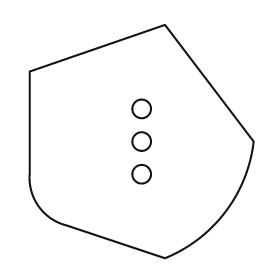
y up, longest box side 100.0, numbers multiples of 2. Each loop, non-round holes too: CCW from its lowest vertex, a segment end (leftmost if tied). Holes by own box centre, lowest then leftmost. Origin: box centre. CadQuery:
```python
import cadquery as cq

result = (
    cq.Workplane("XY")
    .moveTo(10.0, -50.0)
    .threePointArc((36.0, -30.0), (48.0, 0.0))
    .lineTo(10.0, 50.0)
    .lineTo(-48.0, 30.0)
    .lineTo(-48.0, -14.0)
    .threePointArc((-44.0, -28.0), (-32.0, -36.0))
    .close()
    .moveTo(0.0, -14.0)
    .circle(4.0)
    .moveTo(0.0, 0.0)
    .circle(4.0)
    .moveTo(0.0, 14.0)
    .circle(4.0)
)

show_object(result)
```